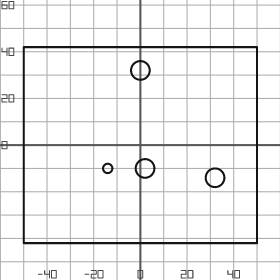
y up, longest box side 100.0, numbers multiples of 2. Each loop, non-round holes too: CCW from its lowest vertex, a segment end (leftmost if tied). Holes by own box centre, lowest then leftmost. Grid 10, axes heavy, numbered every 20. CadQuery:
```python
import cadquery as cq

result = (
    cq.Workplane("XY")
    .moveTo(-50.0, -42.0)
    .lineTo(50.0, -42.0)
    .lineTo(50.0, 42.0)
    .lineTo(-50.0, 42.0)
    .close()
    .moveTo(32.0, -14.0)
    .circle(4.0)
    .moveTo(-14.0, -10.0)
    .circle(2.0)
    .moveTo(2.0, -10.0)
    .circle(4.0)
    .moveTo(0.0, 32.0)
    .circle(4.0)
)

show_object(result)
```